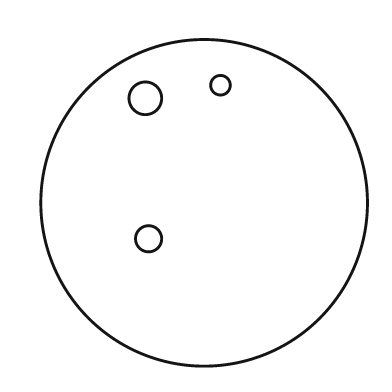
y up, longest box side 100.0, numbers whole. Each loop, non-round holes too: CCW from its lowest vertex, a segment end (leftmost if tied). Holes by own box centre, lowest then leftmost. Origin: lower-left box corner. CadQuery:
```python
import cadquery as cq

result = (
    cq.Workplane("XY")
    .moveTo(50.0, 50.0)
    .circle(50.0)
    .moveTo(33.0, 39.0)
    .circle(4.0)
    .moveTo(32.0, 82.0)
    .circle(5.0)
    .moveTo(55.0, 86.0)
    .circle(3.0)
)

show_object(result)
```